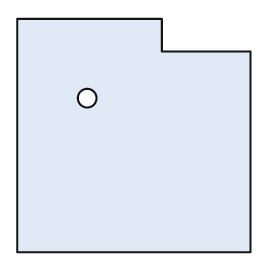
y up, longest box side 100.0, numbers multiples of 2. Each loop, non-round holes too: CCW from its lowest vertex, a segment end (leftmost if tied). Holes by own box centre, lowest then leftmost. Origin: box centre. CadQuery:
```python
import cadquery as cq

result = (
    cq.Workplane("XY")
    .moveTo(-50.0, -50.0)
    .lineTo(50.0, -50.0)
    .lineTo(50.0, 36.0)
    .lineTo(12.0, 36.0)
    .lineTo(12.0, 50.0)
    .lineTo(-50.0, 50.0)
    .close()
    .moveTo(-20.0, 16.0)
    .circle(4.0)
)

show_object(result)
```